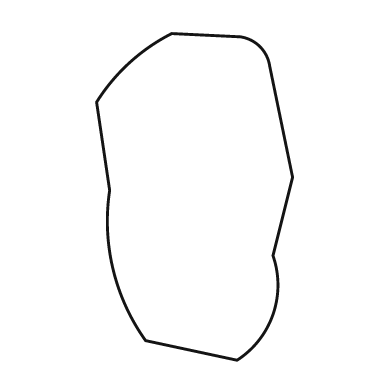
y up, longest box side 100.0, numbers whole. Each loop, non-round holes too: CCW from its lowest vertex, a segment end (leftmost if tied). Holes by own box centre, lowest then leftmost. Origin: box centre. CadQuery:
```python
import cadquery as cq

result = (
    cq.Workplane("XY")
    .moveTo(13.0, -50.0)
    .threePointArc((24.0, -36.0), (24.0, -18.0))
    .lineTo(30.0, 6.0)
    .lineTo(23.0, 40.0)
    .threePointArc((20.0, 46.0), (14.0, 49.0))
    .lineTo(-7.0, 50.0)
    .threePointArc((-20.0, 41.0), (-30.0, 29.0))
    .lineTo(-26.0, 2.0)
    .threePointArc((-25.0, -22.0), (-15.0, -44.0))
    .close()
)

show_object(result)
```